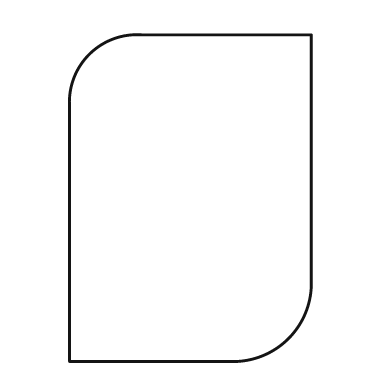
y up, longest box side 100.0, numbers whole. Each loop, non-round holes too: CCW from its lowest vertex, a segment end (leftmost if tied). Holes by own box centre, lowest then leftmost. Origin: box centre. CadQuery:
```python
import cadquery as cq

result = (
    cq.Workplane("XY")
    .moveTo(-37.0, -50.0)
    .lineTo(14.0, -50.0)
    .threePointArc((30.0, -43.0), (37.0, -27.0))
    .lineTo(37.0, 50.0)
    .lineTo(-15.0, 50.0)
    .threePointArc((-31.0, 44.0), (-37.0, 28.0))
    .close()
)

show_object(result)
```